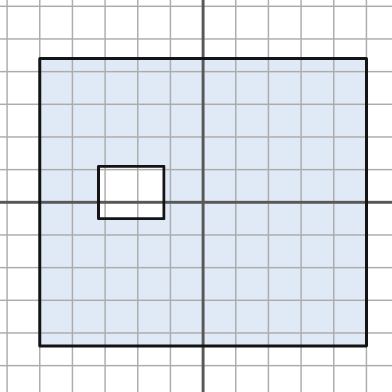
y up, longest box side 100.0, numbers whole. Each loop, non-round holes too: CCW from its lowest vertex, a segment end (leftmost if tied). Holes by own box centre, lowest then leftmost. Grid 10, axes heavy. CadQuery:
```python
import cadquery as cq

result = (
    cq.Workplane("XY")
    .moveTo(-50.0, -44.0)
    .lineTo(50.0, -44.0)
    .lineTo(50.0, 44.0)
    .lineTo(-50.0, 44.0)
    .close()
    .moveTo(-32.0, -5.0)
    .lineTo(-12.0, -5.0)
    .lineTo(-12.0, 11.0)
    .lineTo(-32.0, 11.0)
    .close()
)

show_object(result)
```